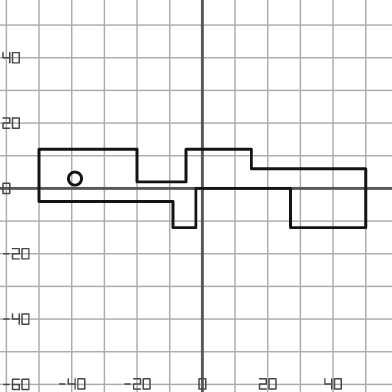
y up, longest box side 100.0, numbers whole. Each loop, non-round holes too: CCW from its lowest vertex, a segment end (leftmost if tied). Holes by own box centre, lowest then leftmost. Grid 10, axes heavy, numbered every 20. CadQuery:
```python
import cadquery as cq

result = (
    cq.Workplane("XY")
    .moveTo(-9.0, -12.0)
    .lineTo(-2.0, -12.0)
    .lineTo(-2.0, 0.0)
    .lineTo(27.0, 0.0)
    .lineTo(27.0, -12.0)
    .lineTo(50.0, -12.0)
    .lineTo(50.0, 6.0)
    .lineTo(15.0, 6.0)
    .lineTo(15.0, 12.0)
    .lineTo(-5.0, 12.0)
    .lineTo(-5.0, 2.0)
    .lineTo(-20.0, 2.0)
    .lineTo(-20.0, 12.0)
    .lineTo(-50.0, 12.0)
    .lineTo(-50.0, -4.0)
    .lineTo(-9.0, -4.0)
    .close()
    .moveTo(-39.0, 3.0)
    .circle(2.0)
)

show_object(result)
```